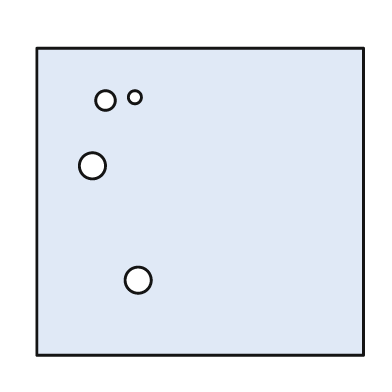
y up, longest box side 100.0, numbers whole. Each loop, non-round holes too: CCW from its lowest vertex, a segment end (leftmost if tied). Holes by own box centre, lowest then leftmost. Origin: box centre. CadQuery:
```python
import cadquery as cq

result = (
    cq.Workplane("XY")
    .moveTo(-50.0, -47.0)
    .lineTo(50.0, -47.0)
    .lineTo(50.0, 47.0)
    .lineTo(-50.0, 47.0)
    .close()
    .moveTo(-19.0, -24.0)
    .circle(4.0)
    .moveTo(-33.0, 11.0)
    .circle(4.0)
    .moveTo(-29.0, 31.0)
    .circle(3.0)
    .moveTo(-20.0, 32.0)
    .circle(2.0)
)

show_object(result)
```